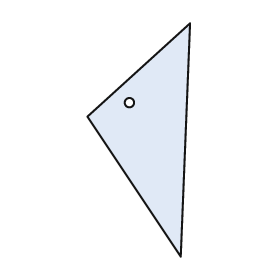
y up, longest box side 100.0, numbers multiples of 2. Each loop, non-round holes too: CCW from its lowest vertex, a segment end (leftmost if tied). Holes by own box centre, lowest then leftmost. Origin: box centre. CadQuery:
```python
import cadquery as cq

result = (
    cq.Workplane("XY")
    .moveTo(18.0, -50.0)
    .lineTo(22.0, 50.0)
    .lineTo(-22.0, 10.0)
    .close()
    .moveTo(-4.0, 16.0)
    .circle(2.0)
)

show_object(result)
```